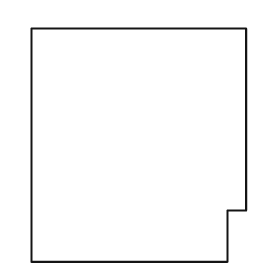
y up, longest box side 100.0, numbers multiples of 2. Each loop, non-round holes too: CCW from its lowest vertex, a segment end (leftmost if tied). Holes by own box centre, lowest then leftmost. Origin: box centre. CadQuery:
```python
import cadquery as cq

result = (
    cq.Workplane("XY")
    .moveTo(-46.0, -50.0)
    .lineTo(38.0, -50.0)
    .lineTo(38.0, -28.0)
    .lineTo(46.0, -28.0)
    .lineTo(46.0, 50.0)
    .lineTo(-46.0, 50.0)
    .close()
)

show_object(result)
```